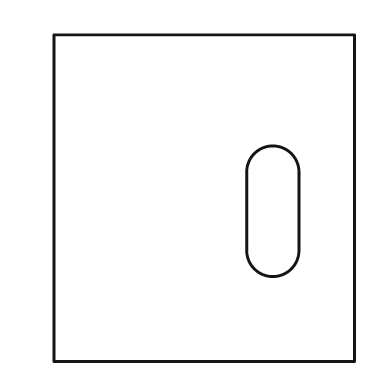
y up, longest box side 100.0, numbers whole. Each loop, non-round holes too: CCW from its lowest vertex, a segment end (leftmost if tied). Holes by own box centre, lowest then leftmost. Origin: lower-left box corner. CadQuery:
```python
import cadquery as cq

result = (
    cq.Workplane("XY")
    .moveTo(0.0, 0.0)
    .lineTo(92.0, 0.0)
    .lineTo(92.0, 100.0)
    .lineTo(0.0, 100.0)
    .close()
    .moveTo(59.0, 34.0)
    .threePointArc((67.0, 26.0), (75.0, 34.0))
    .lineTo(75.0, 58.0)
    .threePointArc((67.0, 66.0), (59.0, 58.0))
    .close()
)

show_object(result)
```